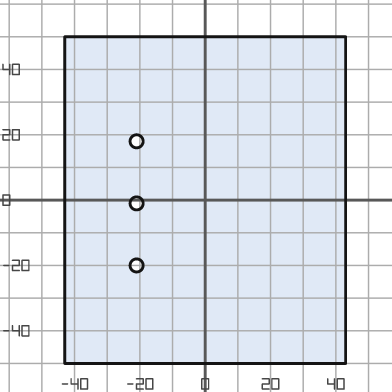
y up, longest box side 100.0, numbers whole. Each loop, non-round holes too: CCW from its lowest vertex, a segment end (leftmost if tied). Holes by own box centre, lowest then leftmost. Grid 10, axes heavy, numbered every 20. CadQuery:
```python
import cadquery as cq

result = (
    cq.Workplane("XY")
    .moveTo(-43.0, -50.0)
    .lineTo(43.0, -50.0)
    .lineTo(43.0, 50.0)
    .lineTo(-43.0, 50.0)
    .close()
    .moveTo(-21.0, -20.0)
    .circle(2.0)
    .moveTo(-21.0, -1.0)
    .circle(2.0)
    .moveTo(-21.0, 18.0)
    .circle(2.0)
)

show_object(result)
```